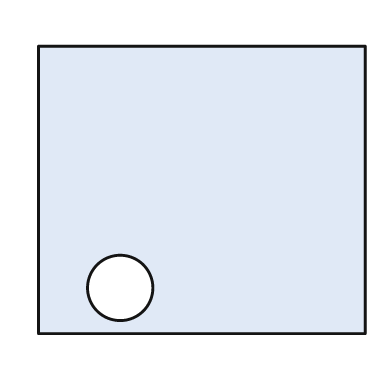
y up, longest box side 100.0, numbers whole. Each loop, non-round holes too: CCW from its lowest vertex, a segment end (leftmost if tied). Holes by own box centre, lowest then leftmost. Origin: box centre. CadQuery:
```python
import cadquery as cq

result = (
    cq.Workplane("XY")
    .moveTo(-50.0, -44.0)
    .lineTo(50.0, -44.0)
    .lineTo(50.0, 44.0)
    .lineTo(-50.0, 44.0)
    .close()
    .moveTo(-25.0, -30.0)
    .circle(10.0)
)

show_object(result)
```